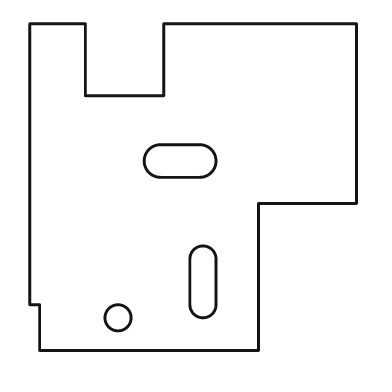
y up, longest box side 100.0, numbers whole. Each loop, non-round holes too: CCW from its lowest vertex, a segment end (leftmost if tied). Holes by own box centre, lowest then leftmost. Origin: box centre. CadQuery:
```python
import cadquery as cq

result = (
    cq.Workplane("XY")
    .moveTo(-47.0, -50.0)
    .lineTo(20.0, -50.0)
    .lineTo(20.0, -5.0)
    .lineTo(50.0, -5.0)
    .lineTo(50.0, 50.0)
    .lineTo(-9.0, 50.0)
    .lineTo(-9.0, 28.0)
    .lineTo(-33.0, 28.0)
    .lineTo(-33.0, 50.0)
    .lineTo(-50.0, 50.0)
    .lineTo(-50.0, -36.0)
    .lineTo(-47.0, -36.0)
    .close()
    .moveTo(-23.0, -40.0)
    .circle(4.0)
    .moveTo(-1.0, -36.0)
    .threePointArc((3.0, -40.0), (7.0, -36.0))
    .lineTo(7.0, -22.0)
    .threePointArc((3.0, -18.0), (-1.0, -22.0))
    .close()
    .moveTo(-10.0, 3.0)
    .lineTo(2.0, 3.0)
    .threePointArc((7.0, 8.0), (2.0, 13.0))
    .lineTo(-10.0, 13.0)
    .threePointArc((-15.0, 8.0), (-10.0, 3.0))
    .close()
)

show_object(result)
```